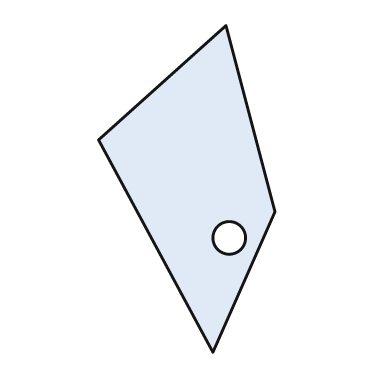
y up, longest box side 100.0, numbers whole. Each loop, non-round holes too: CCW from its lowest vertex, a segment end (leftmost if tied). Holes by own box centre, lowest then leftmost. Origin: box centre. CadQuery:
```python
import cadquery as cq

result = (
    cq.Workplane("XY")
    .moveTo(8.0, -50.0)
    .lineTo(27.0, -7.0)
    .lineTo(12.0, 50.0)
    .lineTo(-27.0, 15.0)
    .close()
    .moveTo(13.0, -15.0)
    .circle(5.0)
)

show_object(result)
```